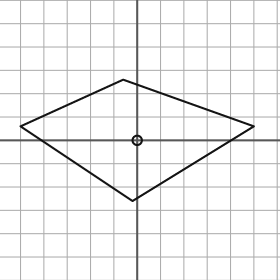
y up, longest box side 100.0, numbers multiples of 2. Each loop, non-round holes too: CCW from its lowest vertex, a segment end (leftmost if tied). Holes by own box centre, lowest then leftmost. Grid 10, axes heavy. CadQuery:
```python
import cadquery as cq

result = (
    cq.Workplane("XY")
    .moveTo(-2.0, -26.0)
    .lineTo(50.0, 6.0)
    .lineTo(-6.0, 26.0)
    .lineTo(-50.0, 6.0)
    .close()
    .moveTo(0.0, 0.0)
    .circle(2.0)
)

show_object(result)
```